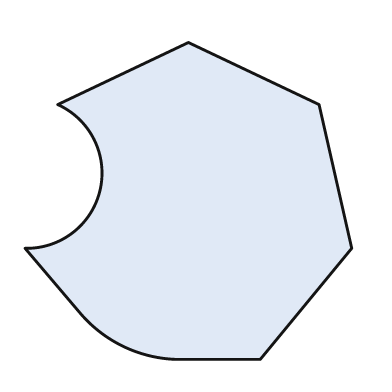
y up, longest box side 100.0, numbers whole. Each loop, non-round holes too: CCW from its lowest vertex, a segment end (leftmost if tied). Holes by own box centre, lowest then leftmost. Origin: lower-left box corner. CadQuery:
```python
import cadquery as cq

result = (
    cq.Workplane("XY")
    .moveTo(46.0, 0.0)
    .lineTo(72.0, 0.0)
    .lineTo(100.0, 34.0)
    .lineTo(90.0, 78.0)
    .lineTo(50.0, 97.0)
    .lineTo(10.0, 78.0)
    .threePointArc((23.0, 52.0), (0.0, 34.0))
    .lineTo(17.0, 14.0)
    .threePointArc((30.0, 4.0), (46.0, 0.0))
    .close()
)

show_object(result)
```